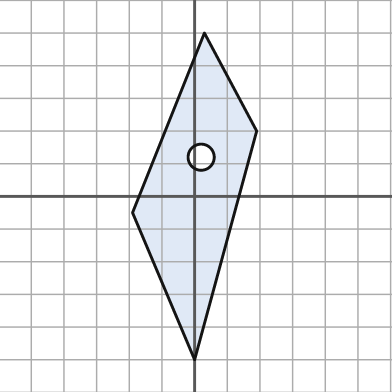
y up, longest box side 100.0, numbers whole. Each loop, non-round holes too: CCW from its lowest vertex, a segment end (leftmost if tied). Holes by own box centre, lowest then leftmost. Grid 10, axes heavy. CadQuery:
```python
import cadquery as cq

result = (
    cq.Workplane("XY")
    .moveTo(0.0, -50.0)
    .lineTo(19.0, 20.0)
    .lineTo(3.0, 50.0)
    .lineTo(-19.0, -5.0)
    .close()
    .moveTo(2.0, 12.0)
    .circle(4.0)
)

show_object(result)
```